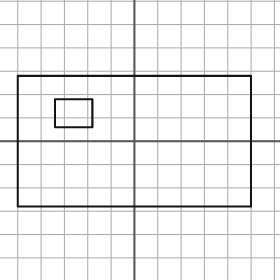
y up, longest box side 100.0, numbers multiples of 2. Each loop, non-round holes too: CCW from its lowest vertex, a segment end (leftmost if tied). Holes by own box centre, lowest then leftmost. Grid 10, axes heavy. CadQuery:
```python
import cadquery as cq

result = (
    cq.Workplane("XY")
    .moveTo(-50.0, -28.0)
    .lineTo(50.0, -28.0)
    .lineTo(50.0, 28.0)
    .lineTo(-50.0, 28.0)
    .close()
    .moveTo(-34.0, 6.0)
    .lineTo(-18.0, 6.0)
    .lineTo(-18.0, 18.0)
    .lineTo(-34.0, 18.0)
    .close()
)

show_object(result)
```